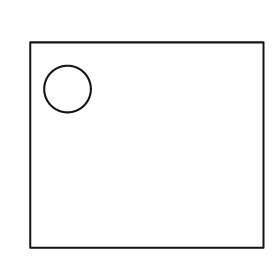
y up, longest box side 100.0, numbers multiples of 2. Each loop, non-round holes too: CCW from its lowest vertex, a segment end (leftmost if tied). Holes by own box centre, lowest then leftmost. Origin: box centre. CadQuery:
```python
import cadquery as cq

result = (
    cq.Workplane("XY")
    .moveTo(-50.0, -44.0)
    .lineTo(50.0, -44.0)
    .lineTo(50.0, 44.0)
    .lineTo(-50.0, 44.0)
    .close()
    .moveTo(-34.0, 24.0)
    .circle(10.0)
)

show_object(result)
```